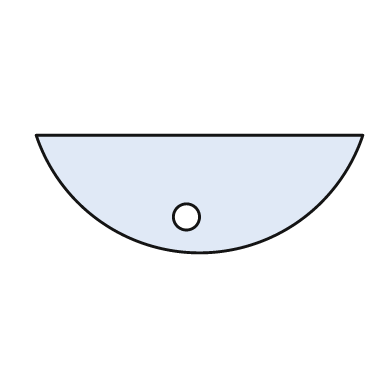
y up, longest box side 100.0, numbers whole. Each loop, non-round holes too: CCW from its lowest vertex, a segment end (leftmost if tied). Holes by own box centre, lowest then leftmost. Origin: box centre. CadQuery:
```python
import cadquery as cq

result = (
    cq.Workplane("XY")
    .moveTo(-50.0, 18.0)
    .threePointArc((0.0, -18.0), (50.0, 18.0))
    .close()
    .moveTo(-4.0, -7.0)
    .circle(4.0)
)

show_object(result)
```